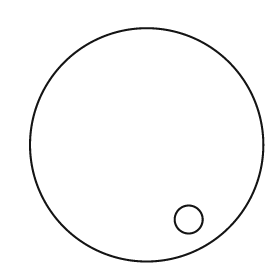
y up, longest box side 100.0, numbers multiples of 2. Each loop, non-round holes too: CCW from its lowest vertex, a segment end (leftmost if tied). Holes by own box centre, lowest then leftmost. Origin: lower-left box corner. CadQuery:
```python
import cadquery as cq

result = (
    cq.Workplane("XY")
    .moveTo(50.0, 50.0)
    .circle(50.0)
    .moveTo(68.0, 18.0)
    .circle(6.0)
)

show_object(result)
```